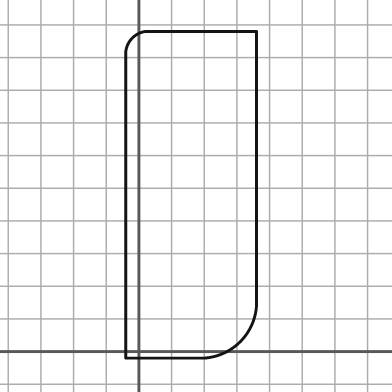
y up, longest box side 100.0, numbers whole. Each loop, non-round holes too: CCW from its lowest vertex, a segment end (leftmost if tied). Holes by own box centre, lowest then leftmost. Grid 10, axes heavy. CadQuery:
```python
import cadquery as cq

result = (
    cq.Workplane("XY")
    .moveTo(-4.0, -2.0)
    .lineTo(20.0, -2.0)
    .threePointArc((31.0, 3.0), (36.0, 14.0))
    .lineTo(36.0, 98.0)
    .lineTo(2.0, 98.0)
    .threePointArc((-2.0, 96.0), (-4.0, 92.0))
    .close()
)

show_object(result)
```